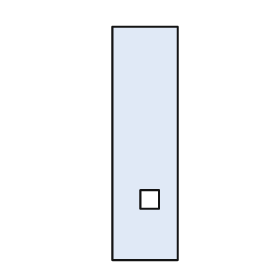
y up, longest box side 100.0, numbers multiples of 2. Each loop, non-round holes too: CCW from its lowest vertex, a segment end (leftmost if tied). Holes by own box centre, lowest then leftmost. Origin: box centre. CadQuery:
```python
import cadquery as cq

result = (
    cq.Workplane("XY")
    .moveTo(-14.0, -50.0)
    .lineTo(14.0, -50.0)
    .lineTo(14.0, 50.0)
    .lineTo(-14.0, 50.0)
    .close()
    .moveTo(-2.0, -28.0)
    .lineTo(6.0, -28.0)
    .lineTo(6.0, -20.0)
    .lineTo(-2.0, -20.0)
    .close()
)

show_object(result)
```